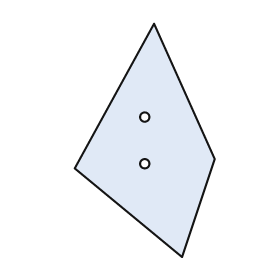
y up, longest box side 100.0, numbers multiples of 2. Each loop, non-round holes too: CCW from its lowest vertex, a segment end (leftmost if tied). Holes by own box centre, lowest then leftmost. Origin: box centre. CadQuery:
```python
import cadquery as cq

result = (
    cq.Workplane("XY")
    .moveTo(16.0, -50.0)
    .lineTo(30.0, -8.0)
    .lineTo(4.0, 50.0)
    .lineTo(-30.0, -12.0)
    .close()
    .moveTo(0.0, -10.0)
    .circle(2.0)
    .moveTo(0.0, 10.0)
    .circle(2.0)
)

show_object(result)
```